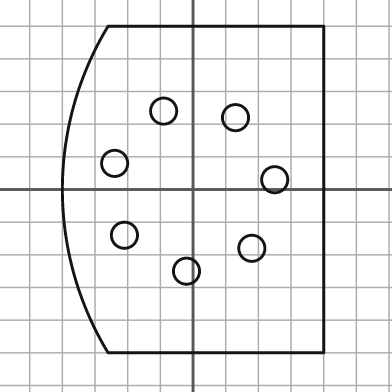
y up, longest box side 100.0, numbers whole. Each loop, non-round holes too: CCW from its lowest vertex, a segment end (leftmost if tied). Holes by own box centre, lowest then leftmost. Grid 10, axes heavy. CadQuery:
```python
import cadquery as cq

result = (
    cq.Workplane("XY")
    .moveTo(-26.0, -50.0)
    .lineTo(40.0, -50.0)
    .lineTo(40.0, 50.0)
    .lineTo(-26.0, 50.0)
    .threePointArc((-40.0, 0.0), (-26.0, -50.0))
    .close()
    .moveTo(-2.0, -25.0)
    .circle(4.0)
    .moveTo(18.0, -18.0)
    .circle(4.0)
    .moveTo(-21.0, -14.0)
    .circle(4.0)
    .moveTo(25.0, 3.0)
    .circle(4.0)
    .moveTo(-24.0, 8.0)
    .circle(4.0)
    .moveTo(13.0, 22.0)
    .circle(4.0)
    .moveTo(-9.0, 24.0)
    .circle(4.0)
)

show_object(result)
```